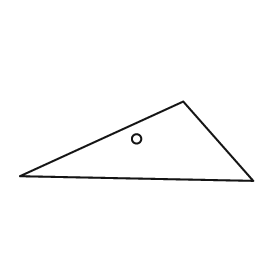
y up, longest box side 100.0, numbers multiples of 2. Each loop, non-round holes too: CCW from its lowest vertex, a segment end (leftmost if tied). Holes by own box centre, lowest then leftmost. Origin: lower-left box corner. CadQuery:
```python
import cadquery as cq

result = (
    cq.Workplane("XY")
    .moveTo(100.0, 0.0)
    .lineTo(70.0, 34.0)
    .lineTo(0.0, 2.0)
    .close()
    .moveTo(50.0, 18.0)
    .circle(2.0)
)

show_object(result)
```